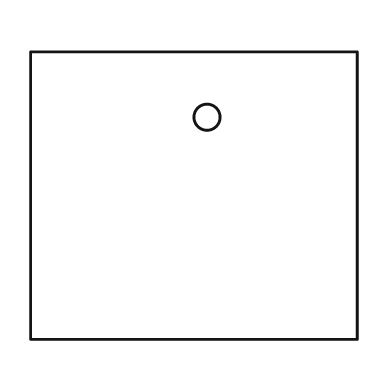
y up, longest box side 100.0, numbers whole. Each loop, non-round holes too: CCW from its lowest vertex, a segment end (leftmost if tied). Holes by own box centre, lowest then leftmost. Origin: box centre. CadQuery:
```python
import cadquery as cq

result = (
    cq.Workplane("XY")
    .moveTo(-50.0, -44.0)
    .lineTo(50.0, -44.0)
    .lineTo(50.0, 44.0)
    .lineTo(-50.0, 44.0)
    .close()
    .moveTo(4.0, 24.0)
    .circle(4.0)
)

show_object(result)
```